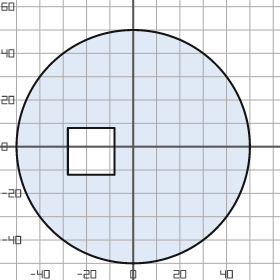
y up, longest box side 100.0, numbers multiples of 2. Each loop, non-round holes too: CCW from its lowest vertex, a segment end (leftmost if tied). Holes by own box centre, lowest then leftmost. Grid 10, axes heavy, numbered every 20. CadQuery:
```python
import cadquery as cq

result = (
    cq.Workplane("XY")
    .moveTo(0.0, 0.0)
    .circle(50.0)
    .moveTo(-28.0, -12.0)
    .lineTo(-8.0, -12.0)
    .lineTo(-8.0, 8.0)
    .lineTo(-28.0, 8.0)
    .close()
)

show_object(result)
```